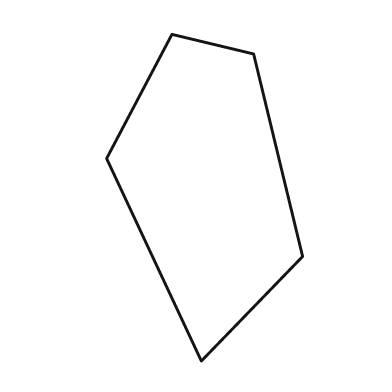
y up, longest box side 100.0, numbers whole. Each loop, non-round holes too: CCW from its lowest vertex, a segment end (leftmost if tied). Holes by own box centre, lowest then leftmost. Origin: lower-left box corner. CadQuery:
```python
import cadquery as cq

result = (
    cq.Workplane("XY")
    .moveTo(29.0, 0.0)
    .lineTo(60.0, 32.0)
    .lineTo(45.0, 94.0)
    .lineTo(20.0, 100.0)
    .lineTo(0.0, 62.0)
    .close()
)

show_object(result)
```